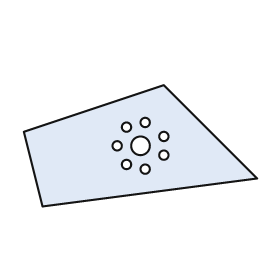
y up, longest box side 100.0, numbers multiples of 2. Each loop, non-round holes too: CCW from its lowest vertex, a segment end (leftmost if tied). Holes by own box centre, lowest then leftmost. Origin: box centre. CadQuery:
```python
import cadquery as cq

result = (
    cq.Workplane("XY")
    .moveTo(-42.0, -26.0)
    .lineTo(50.0, -14.0)
    .lineTo(10.0, 26.0)
    .lineTo(-50.0, 6.0)
    .close()
    .moveTo(2.0, -10.0)
    .circle(2.0)
    .moveTo(-6.0, -8.0)
    .circle(2.0)
    .moveTo(10.0, -4.0)
    .circle(2.0)
    .moveTo(-10.0, 0.0)
    .circle(2.0)
    .moveTo(0.0, 0.0)
    .circle(4.0)
    .moveTo(10.0, 4.0)
    .circle(2.0)
    .moveTo(-6.0, 8.0)
    .circle(2.0)
    .moveTo(2.0, 10.0)
    .circle(2.0)
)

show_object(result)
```